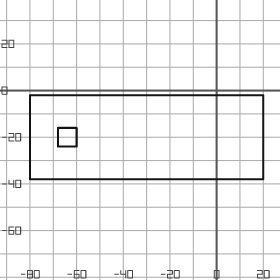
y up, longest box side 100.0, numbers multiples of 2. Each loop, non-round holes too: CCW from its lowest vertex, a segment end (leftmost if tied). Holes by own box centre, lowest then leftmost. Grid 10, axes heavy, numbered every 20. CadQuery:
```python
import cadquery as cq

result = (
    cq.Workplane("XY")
    .moveTo(-80.0, -38.0)
    .lineTo(20.0, -38.0)
    .lineTo(20.0, -2.0)
    .lineTo(-80.0, -2.0)
    .close()
    .moveTo(-68.0, -24.0)
    .lineTo(-60.0, -24.0)
    .lineTo(-60.0, -16.0)
    .lineTo(-68.0, -16.0)
    .close()
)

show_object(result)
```